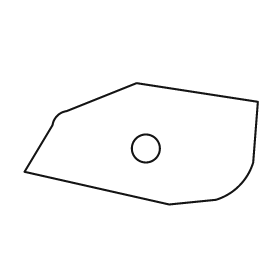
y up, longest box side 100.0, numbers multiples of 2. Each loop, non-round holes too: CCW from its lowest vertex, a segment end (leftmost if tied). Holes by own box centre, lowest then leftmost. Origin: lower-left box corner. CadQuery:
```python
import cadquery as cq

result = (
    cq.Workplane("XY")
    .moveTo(62.0, 0.0)
    .lineTo(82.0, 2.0)
    .threePointArc((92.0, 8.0), (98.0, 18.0))
    .lineTo(100.0, 44.0)
    .lineTo(48.0, 52.0)
    .lineTo(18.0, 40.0)
    .threePointArc((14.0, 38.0), (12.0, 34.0))
    .lineTo(0.0, 14.0)
    .close()
    .moveTo(52.0, 24.0)
    .circle(6.0)
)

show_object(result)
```